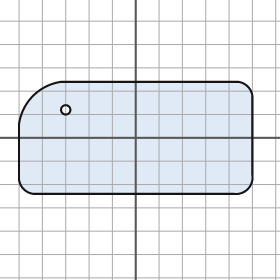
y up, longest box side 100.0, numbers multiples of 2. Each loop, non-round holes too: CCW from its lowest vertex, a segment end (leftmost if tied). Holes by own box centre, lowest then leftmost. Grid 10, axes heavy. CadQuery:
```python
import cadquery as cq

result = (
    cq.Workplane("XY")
    .moveTo(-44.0, -24.0)
    .lineTo(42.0, -24.0)
    .threePointArc((48.0, -22.0), (50.0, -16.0))
    .lineTo(50.0, 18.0)
    .threePointArc((48.0, 22.0), (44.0, 24.0))
    .lineTo(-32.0, 24.0)
    .threePointArc((-44.0, 18.0), (-50.0, 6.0))
    .lineTo(-50.0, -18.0)
    .threePointArc((-48.0, -22.0), (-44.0, -24.0))
    .close()
    .moveTo(-30.0, 12.0)
    .circle(2.0)
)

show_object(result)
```